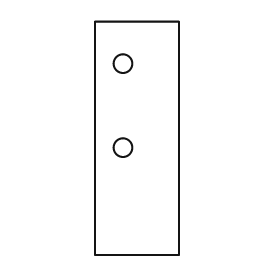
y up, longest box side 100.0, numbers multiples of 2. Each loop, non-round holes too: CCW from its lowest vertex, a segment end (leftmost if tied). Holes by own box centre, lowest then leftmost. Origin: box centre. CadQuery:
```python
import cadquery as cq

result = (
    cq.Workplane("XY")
    .moveTo(-18.0, -50.0)
    .lineTo(18.0, -50.0)
    .lineTo(18.0, 50.0)
    .lineTo(-18.0, 50.0)
    .close()
    .moveTo(-6.0, -4.0)
    .circle(4.0)
    .moveTo(-6.0, 32.0)
    .circle(4.0)
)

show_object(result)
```